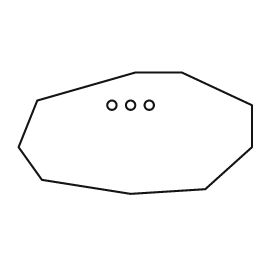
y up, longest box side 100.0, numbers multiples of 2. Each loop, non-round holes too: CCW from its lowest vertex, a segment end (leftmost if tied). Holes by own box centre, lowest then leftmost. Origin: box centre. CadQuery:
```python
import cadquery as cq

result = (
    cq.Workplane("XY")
    .moveTo(-2.0, -26.0)
    .lineTo(30.0, -24.0)
    .lineTo(50.0, -6.0)
    .lineTo(50.0, 12.0)
    .lineTo(20.0, 26.0)
    .lineTo(0.0, 26.0)
    .lineTo(-42.0, 14.0)
    .lineTo(-50.0, -6.0)
    .lineTo(-40.0, -20.0)
    .close()
    .moveTo(-10.0, 12.0)
    .circle(2.0)
    .moveTo(-2.0, 12.0)
    .circle(2.0)
    .moveTo(6.0, 12.0)
    .circle(2.0)
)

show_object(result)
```